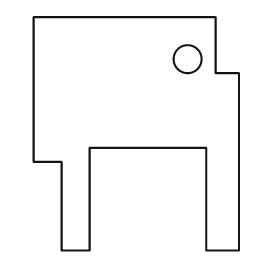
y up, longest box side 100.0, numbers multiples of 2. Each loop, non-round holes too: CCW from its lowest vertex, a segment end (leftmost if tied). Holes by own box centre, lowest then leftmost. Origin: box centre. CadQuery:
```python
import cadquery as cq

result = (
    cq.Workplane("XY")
    .moveTo(-32.0, -50.0)
    .lineTo(-20.0, -50.0)
    .lineTo(-20.0, -6.0)
    .lineTo(30.0, -6.0)
    .lineTo(30.0, -50.0)
    .lineTo(44.0, -50.0)
    .lineTo(44.0, 26.0)
    .lineTo(34.0, 26.0)
    .lineTo(34.0, 50.0)
    .lineTo(-44.0, 50.0)
    .lineTo(-44.0, -12.0)
    .lineTo(-32.0, -12.0)
    .close()
    .moveTo(22.0, 32.0)
    .circle(6.0)
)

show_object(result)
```